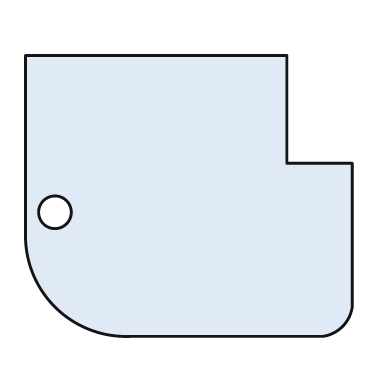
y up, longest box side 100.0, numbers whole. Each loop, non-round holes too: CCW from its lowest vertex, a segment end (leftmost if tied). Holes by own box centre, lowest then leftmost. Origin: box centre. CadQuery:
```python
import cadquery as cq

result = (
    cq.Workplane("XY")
    .moveTo(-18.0, -43.0)
    .lineTo(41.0, -43.0)
    .threePointArc((47.0, -40.0), (50.0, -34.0))
    .lineTo(50.0, 10.0)
    .lineTo(30.0, 10.0)
    .lineTo(30.0, 43.0)
    .lineTo(-50.0, 43.0)
    .lineTo(-50.0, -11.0)
    .threePointArc((-41.0, -34.0), (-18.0, -43.0))
    .close()
    .moveTo(-41.0, -5.0)
    .circle(5.0)
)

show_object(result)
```